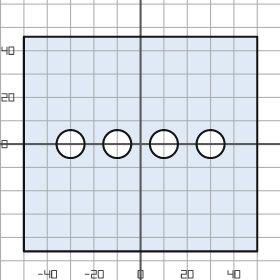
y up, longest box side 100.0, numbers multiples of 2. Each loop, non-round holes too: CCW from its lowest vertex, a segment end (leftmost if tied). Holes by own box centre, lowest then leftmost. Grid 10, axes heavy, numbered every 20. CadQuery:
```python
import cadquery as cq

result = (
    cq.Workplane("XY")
    .moveTo(-50.0, -46.0)
    .lineTo(50.0, -46.0)
    .lineTo(50.0, 46.0)
    .lineTo(-50.0, 46.0)
    .close()
    .moveTo(-30.0, 0.0)
    .circle(6.0)
    .moveTo(-10.0, 0.0)
    .circle(6.0)
    .moveTo(10.0, 0.0)
    .circle(6.0)
    .moveTo(30.0, 0.0)
    .circle(6.0)
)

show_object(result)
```